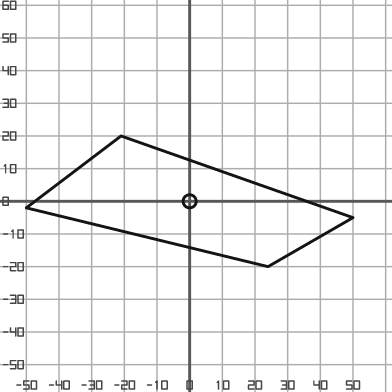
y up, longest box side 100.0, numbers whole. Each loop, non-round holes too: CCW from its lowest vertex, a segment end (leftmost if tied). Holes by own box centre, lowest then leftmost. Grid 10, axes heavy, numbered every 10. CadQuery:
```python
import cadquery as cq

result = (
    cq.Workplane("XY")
    .moveTo(24.0, -20.0)
    .lineTo(50.0, -5.0)
    .lineTo(-21.0, 20.0)
    .lineTo(-50.0, -2.0)
    .close()
    .moveTo(0.0, 0.0)
    .circle(2.0)
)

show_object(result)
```